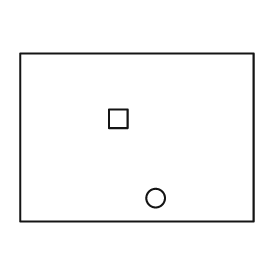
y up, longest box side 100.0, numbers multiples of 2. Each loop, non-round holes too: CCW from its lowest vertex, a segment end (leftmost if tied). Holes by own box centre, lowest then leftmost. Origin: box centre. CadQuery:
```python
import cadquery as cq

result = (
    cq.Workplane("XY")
    .moveTo(-50.0, -36.0)
    .lineTo(50.0, -36.0)
    .lineTo(50.0, 36.0)
    .lineTo(-50.0, 36.0)
    .close()
    .moveTo(8.0, -26.0)
    .circle(4.0)
    .moveTo(-12.0, 4.0)
    .lineTo(-4.0, 4.0)
    .lineTo(-4.0, 12.0)
    .lineTo(-12.0, 12.0)
    .close()
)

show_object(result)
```